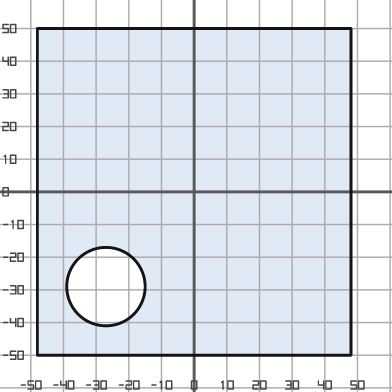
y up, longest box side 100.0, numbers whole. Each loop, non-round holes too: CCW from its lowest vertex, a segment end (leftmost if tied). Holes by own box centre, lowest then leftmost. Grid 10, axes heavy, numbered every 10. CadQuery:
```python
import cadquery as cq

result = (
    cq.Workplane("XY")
    .moveTo(-48.0, -50.0)
    .lineTo(48.0, -50.0)
    .lineTo(48.0, 50.0)
    .lineTo(-48.0, 50.0)
    .close()
    .moveTo(-27.0, -29.0)
    .circle(12.0)
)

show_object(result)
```